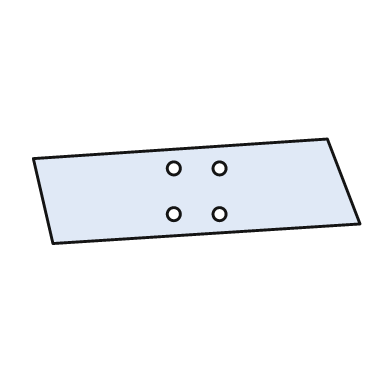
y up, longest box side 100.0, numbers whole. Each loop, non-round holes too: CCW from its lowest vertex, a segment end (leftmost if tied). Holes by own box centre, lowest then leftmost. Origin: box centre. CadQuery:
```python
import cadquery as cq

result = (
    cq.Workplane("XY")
    .moveTo(-44.0, -16.0)
    .lineTo(50.0, -10.0)
    .lineTo(40.0, 16.0)
    .lineTo(-50.0, 10.0)
    .close()
    .moveTo(-7.0, -7.0)
    .circle(2.0)
    .moveTo(7.0, -7.0)
    .circle(2.0)
    .moveTo(-7.0, 7.0)
    .circle(2.0)
    .moveTo(7.0, 7.0)
    .circle(2.0)
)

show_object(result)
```